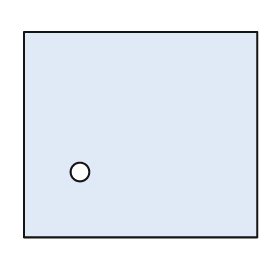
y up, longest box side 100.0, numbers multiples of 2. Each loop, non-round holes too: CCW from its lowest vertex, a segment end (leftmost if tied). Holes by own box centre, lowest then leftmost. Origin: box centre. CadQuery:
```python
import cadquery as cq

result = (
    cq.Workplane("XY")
    .moveTo(-50.0, -44.0)
    .lineTo(50.0, -44.0)
    .lineTo(50.0, 44.0)
    .lineTo(-50.0, 44.0)
    .close()
    .moveTo(-26.0, -16.0)
    .circle(4.0)
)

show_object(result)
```